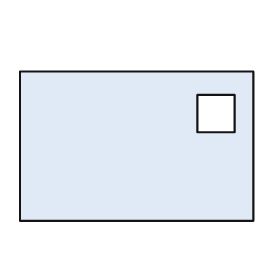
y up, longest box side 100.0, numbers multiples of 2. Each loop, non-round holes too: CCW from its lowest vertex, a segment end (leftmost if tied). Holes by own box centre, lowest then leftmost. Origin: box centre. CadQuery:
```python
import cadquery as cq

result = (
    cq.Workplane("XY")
    .moveTo(-50.0, -32.0)
    .lineTo(50.0, -32.0)
    .lineTo(50.0, 32.0)
    .lineTo(-50.0, 32.0)
    .close()
    .moveTo(26.0, 6.0)
    .lineTo(42.0, 6.0)
    .lineTo(42.0, 22.0)
    .lineTo(26.0, 22.0)
    .close()
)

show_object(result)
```